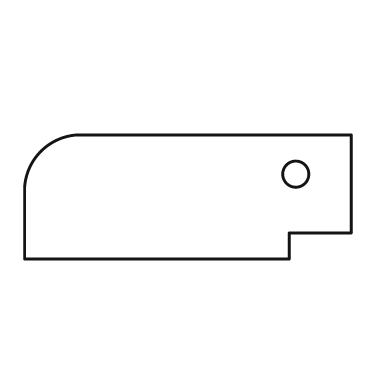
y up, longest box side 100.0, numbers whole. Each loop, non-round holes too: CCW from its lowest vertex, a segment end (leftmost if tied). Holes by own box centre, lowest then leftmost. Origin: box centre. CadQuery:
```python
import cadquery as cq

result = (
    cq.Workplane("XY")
    .moveTo(-50.0, -19.0)
    .lineTo(31.0, -19.0)
    .lineTo(31.0, -11.0)
    .lineTo(50.0, -11.0)
    .lineTo(50.0, 19.0)
    .lineTo(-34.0, 19.0)
    .threePointArc((-45.0, 14.0), (-50.0, 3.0))
    .close()
    .moveTo(33.0, 7.0)
    .circle(4.0)
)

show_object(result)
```